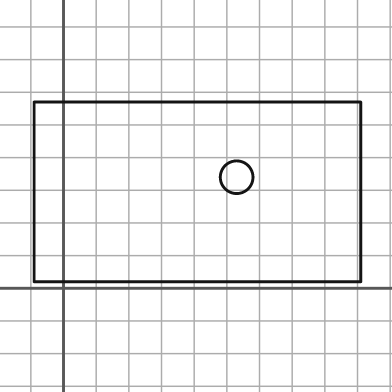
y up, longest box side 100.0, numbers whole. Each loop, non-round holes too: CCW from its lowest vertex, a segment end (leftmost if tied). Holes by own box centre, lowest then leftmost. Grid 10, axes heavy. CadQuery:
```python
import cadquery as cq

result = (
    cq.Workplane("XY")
    .moveTo(-9.0, 2.0)
    .lineTo(91.0, 2.0)
    .lineTo(91.0, 57.0)
    .lineTo(-9.0, 57.0)
    .close()
    .moveTo(53.0, 34.0)
    .circle(5.0)
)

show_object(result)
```